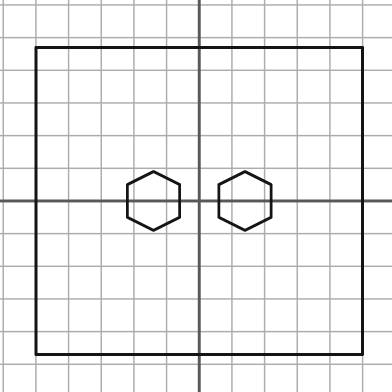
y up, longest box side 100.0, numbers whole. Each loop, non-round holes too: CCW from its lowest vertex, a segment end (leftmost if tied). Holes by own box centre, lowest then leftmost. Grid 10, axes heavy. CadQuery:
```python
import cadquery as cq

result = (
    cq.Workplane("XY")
    .moveTo(-50.0, -47.0)
    .lineTo(50.0, -47.0)
    .lineTo(50.0, 47.0)
    .lineTo(-50.0, 47.0)
    .close()
    .moveTo(-14.0, -9.0)
    .lineTo(-6.0, -5.0)
    .lineTo(-6.0, 5.0)
    .lineTo(-14.0, 9.0)
    .lineTo(-22.0, 5.0)
    .lineTo(-22.0, -5.0)
    .close()
    .moveTo(14.0, -9.0)
    .lineTo(22.0, -5.0)
    .lineTo(22.0, 5.0)
    .lineTo(14.0, 9.0)
    .lineTo(6.0, 5.0)
    .lineTo(6.0, -5.0)
    .close()
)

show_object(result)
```